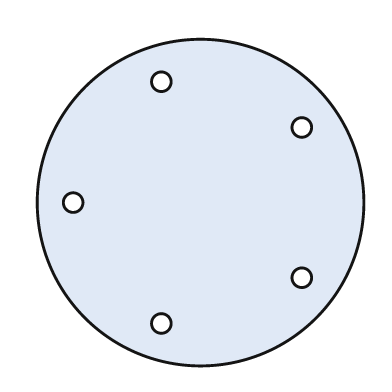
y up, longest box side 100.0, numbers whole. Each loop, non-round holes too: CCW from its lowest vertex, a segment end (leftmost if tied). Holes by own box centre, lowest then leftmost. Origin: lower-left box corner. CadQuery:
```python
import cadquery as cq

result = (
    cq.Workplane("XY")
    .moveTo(50.0, 50.0)
    .circle(50.0)
    .moveTo(38.0, 13.0)
    .circle(3.0)
    .moveTo(81.0, 27.0)
    .circle(3.0)
    .moveTo(11.0, 50.0)
    .circle(3.0)
    .moveTo(81.0, 73.0)
    .circle(3.0)
    .moveTo(38.0, 87.0)
    .circle(3.0)
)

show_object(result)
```